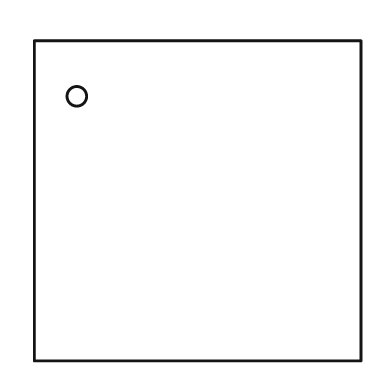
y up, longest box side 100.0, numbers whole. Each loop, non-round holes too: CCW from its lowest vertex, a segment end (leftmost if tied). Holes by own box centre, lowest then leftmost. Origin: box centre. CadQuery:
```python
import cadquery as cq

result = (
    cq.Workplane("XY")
    .moveTo(-50.0, -49.0)
    .lineTo(50.0, -49.0)
    .lineTo(50.0, 49.0)
    .lineTo(-50.0, 49.0)
    .close()
    .moveTo(-37.0, 32.0)
    .circle(3.0)
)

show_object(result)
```